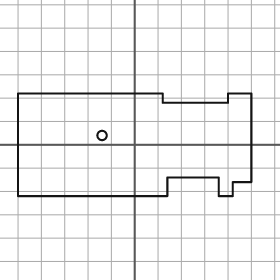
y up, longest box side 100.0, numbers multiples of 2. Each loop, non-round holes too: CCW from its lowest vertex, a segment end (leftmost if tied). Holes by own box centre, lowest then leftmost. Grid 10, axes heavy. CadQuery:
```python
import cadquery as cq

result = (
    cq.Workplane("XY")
    .moveTo(-50.0, -22.0)
    .lineTo(14.0, -22.0)
    .lineTo(14.0, -14.0)
    .lineTo(36.0, -14.0)
    .lineTo(36.0, -22.0)
    .lineTo(42.0, -22.0)
    .lineTo(42.0, -16.0)
    .lineTo(50.0, -16.0)
    .lineTo(50.0, 22.0)
    .lineTo(40.0, 22.0)
    .lineTo(40.0, 18.0)
    .lineTo(12.0, 18.0)
    .lineTo(12.0, 22.0)
    .lineTo(-50.0, 22.0)
    .close()
    .moveTo(-14.0, 4.0)
    .circle(2.0)
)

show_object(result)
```